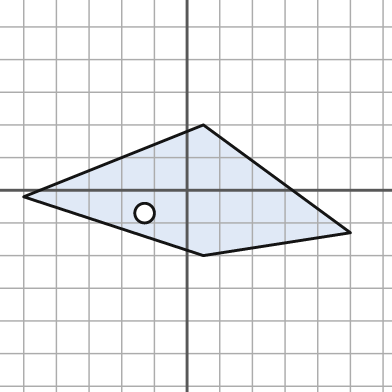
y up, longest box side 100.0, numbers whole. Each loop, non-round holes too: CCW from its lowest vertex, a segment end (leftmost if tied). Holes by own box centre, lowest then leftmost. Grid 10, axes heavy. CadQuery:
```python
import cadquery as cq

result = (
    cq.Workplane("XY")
    .moveTo(5.0, -20.0)
    .lineTo(50.0, -13.0)
    .lineTo(5.0, 20.0)
    .lineTo(-50.0, -2.0)
    .close()
    .moveTo(-13.0, -7.0)
    .circle(3.0)
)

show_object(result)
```